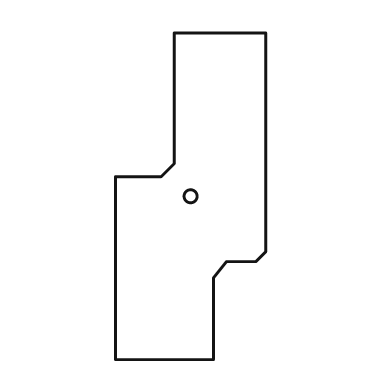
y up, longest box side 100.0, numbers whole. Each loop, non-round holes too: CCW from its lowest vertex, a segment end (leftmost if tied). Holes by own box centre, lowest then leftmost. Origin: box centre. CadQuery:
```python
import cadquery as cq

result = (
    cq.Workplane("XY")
    .moveTo(-23.0, -50.0)
    .lineTo(7.0, -50.0)
    .lineTo(7.0, -25.0)
    .lineTo(11.0, -20.0)
    .lineTo(20.0, -20.0)
    .lineTo(23.0, -17.0)
    .lineTo(23.0, 50.0)
    .lineTo(-5.0, 50.0)
    .lineTo(-5.0, 10.0)
    .lineTo(-9.0, 6.0)
    .lineTo(-23.0, 6.0)
    .close()
    .moveTo(0.0, 0.0)
    .circle(2.0)
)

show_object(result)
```